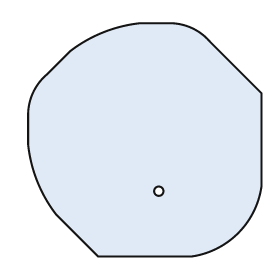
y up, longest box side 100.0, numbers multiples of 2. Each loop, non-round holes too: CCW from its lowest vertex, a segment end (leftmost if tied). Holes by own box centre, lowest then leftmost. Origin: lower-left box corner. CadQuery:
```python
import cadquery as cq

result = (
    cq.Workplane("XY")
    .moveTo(30.0, 0.0)
    .lineTo(70.0, 0.0)
    .threePointArc((90.0, 10.0), (100.0, 30.0))
    .lineTo(100.0, 70.0)
    .lineTo(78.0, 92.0)
    .threePointArc((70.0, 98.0), (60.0, 100.0))
    .lineTo(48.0, 100.0)
    .threePointArc((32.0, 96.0), (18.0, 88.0))
    .lineTo(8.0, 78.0)
    .threePointArc((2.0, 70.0), (0.0, 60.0))
    .lineTo(0.0, 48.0)
    .threePointArc((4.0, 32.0), (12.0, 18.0))
    .close()
    .moveTo(56.0, 28.0)
    .circle(2.0)
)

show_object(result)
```